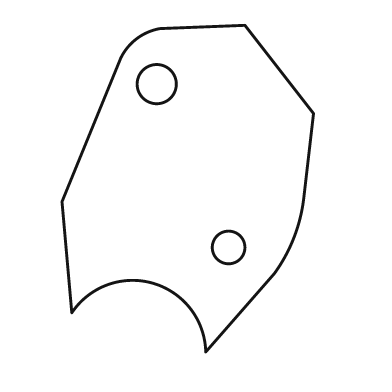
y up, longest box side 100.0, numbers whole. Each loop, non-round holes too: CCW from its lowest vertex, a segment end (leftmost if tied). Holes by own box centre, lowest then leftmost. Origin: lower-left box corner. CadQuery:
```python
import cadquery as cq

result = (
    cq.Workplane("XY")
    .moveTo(44.0, 0.0)
    .lineTo(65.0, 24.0)
    .threePointArc((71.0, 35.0), (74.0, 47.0))
    .lineTo(77.0, 73.0)
    .lineTo(56.0, 100.0)
    .lineTo(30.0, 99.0)
    .threePointArc((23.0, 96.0), (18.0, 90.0))
    .lineTo(0.0, 46.0)
    .lineTo(3.0, 12.0)
    .threePointArc((28.0, 21.0), (44.0, 0.0))
    .close()
    .moveTo(51.0, 32.0)
    .circle(5.0)
    .moveTo(29.0, 82.0)
    .circle(6.0)
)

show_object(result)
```